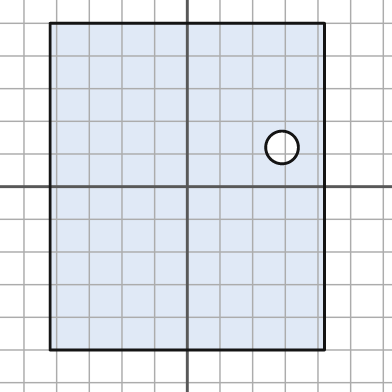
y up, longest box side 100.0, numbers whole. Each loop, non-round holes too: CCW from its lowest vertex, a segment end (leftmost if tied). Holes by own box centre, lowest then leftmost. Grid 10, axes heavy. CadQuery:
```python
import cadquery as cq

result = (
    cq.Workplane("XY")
    .moveTo(-42.0, -50.0)
    .lineTo(42.0, -50.0)
    .lineTo(42.0, 50.0)
    .lineTo(-42.0, 50.0)
    .close()
    .moveTo(29.0, 12.0)
    .circle(5.0)
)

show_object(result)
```